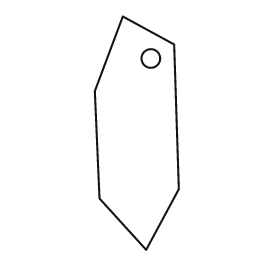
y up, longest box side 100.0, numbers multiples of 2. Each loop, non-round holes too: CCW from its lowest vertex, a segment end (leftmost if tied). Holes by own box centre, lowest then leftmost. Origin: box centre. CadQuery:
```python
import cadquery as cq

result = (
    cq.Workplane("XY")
    .moveTo(4.0, -50.0)
    .lineTo(18.0, -24.0)
    .lineTo(16.0, 38.0)
    .lineTo(-6.0, 50.0)
    .lineTo(-18.0, 18.0)
    .lineTo(-16.0, -28.0)
    .close()
    .moveTo(6.0, 32.0)
    .circle(4.0)
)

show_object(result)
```